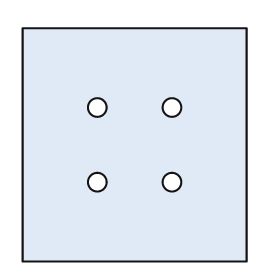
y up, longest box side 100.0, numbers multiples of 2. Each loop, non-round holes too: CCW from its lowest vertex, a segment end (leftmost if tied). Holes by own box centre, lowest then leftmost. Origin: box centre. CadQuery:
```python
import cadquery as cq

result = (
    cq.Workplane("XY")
    .moveTo(-48.0, -50.0)
    .lineTo(48.0, -50.0)
    .lineTo(48.0, 50.0)
    .lineTo(-48.0, 50.0)
    .close()
    .moveTo(-16.0, -16.0)
    .circle(4.0)
    .moveTo(16.0, -16.0)
    .circle(4.0)
    .moveTo(-16.0, 16.0)
    .circle(4.0)
    .moveTo(16.0, 16.0)
    .circle(4.0)
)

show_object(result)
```